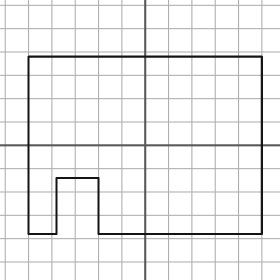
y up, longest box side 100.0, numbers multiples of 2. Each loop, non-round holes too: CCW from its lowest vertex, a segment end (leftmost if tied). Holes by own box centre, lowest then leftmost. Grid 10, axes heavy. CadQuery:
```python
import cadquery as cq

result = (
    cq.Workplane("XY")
    .moveTo(-50.0, -38.0)
    .lineTo(-38.0, -38.0)
    .lineTo(-38.0, -14.0)
    .lineTo(-20.0, -14.0)
    .lineTo(-20.0, -38.0)
    .lineTo(50.0, -38.0)
    .lineTo(50.0, 38.0)
    .lineTo(-50.0, 38.0)
    .close()
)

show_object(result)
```